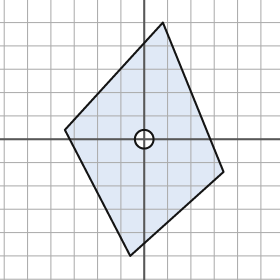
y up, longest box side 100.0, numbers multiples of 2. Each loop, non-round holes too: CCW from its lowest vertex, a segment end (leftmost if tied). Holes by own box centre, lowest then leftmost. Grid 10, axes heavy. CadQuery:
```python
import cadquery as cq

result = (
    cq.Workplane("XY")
    .moveTo(-6.0, -50.0)
    .lineTo(34.0, -14.0)
    .lineTo(8.0, 50.0)
    .lineTo(-34.0, 4.0)
    .close()
    .moveTo(0.0, 0.0)
    .circle(4.0)
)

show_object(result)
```